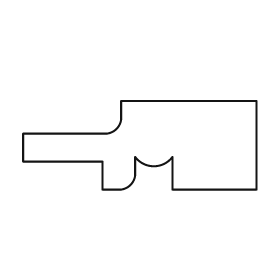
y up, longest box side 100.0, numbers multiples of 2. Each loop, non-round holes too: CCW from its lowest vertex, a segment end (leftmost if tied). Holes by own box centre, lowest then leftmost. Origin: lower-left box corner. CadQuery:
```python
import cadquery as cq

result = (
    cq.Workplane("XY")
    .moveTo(34.0, 0.0)
    .lineTo(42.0, 0.0)
    .threePointArc((46.0, 2.0), (48.0, 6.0))
    .lineTo(48.0, 14.0)
    .threePointArc((56.0, 10.0), (64.0, 14.0))
    .lineTo(64.0, 0.0)
    .lineTo(100.0, 0.0)
    .lineTo(100.0, 38.0)
    .lineTo(42.0, 38.0)
    .lineTo(42.0, 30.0)
    .threePointArc((40.0, 26.0), (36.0, 24.0))
    .lineTo(0.0, 24.0)
    .lineTo(0.0, 12.0)
    .lineTo(34.0, 12.0)
    .close()
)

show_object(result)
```